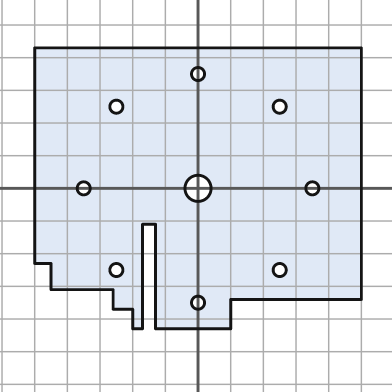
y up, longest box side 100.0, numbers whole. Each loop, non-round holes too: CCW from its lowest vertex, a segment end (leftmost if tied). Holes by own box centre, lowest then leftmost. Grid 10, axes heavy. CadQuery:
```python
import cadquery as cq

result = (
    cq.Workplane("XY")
    .moveTo(-20.0, -43.0)
    .lineTo(-17.0, -43.0)
    .lineTo(-17.0, -11.0)
    .lineTo(-13.0, -11.0)
    .lineTo(-13.0, -43.0)
    .lineTo(10.0, -43.0)
    .lineTo(10.0, -34.0)
    .lineTo(50.0, -34.0)
    .lineTo(50.0, 43.0)
    .lineTo(-50.0, 43.0)
    .lineTo(-50.0, -23.0)
    .lineTo(-45.0, -23.0)
    .lineTo(-45.0, -31.0)
    .lineTo(-26.0, -31.0)
    .lineTo(-26.0, -37.0)
    .lineTo(-20.0, -37.0)
    .close()
    .moveTo(0.0, -35.0)
    .circle(2.0)
    .moveTo(-25.0, -25.0)
    .circle(2.0)
    .moveTo(25.0, -25.0)
    .circle(2.0)
    .moveTo(-35.0, 0.0)
    .circle(2.0)
    .moveTo(0.0, 0.0)
    .circle(4.0)
    .moveTo(35.0, 0.0)
    .circle(2.0)
    .moveTo(-25.0, 25.0)
    .circle(2.0)
    .moveTo(25.0, 25.0)
    .circle(2.0)
    .moveTo(0.0, 35.0)
    .circle(2.0)
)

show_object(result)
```